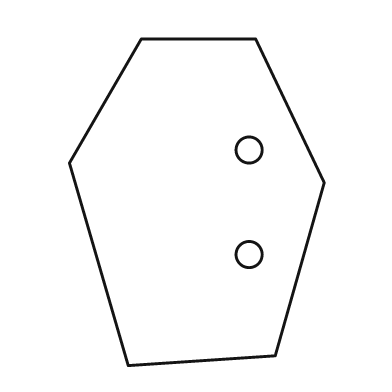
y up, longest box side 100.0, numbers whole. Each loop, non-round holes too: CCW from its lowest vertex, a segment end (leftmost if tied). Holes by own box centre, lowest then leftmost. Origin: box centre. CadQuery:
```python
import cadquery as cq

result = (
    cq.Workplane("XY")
    .moveTo(-21.0, -50.0)
    .lineTo(24.0, -47.0)
    .lineTo(39.0, 6.0)
    .lineTo(18.0, 50.0)
    .lineTo(-17.0, 50.0)
    .lineTo(-39.0, 12.0)
    .close()
    .moveTo(16.0, -16.0)
    .circle(4.0)
    .moveTo(16.0, 16.0)
    .circle(4.0)
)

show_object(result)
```